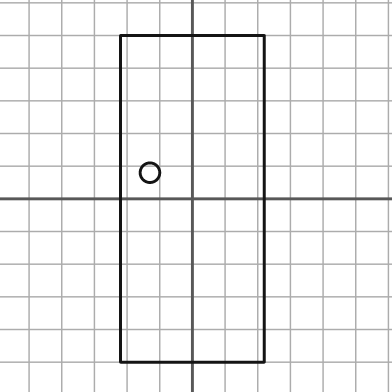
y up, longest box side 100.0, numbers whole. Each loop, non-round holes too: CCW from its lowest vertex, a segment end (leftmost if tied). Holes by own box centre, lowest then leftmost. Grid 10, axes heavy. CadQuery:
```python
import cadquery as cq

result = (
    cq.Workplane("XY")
    .moveTo(-22.0, -50.0)
    .lineTo(22.0, -50.0)
    .lineTo(22.0, 50.0)
    .lineTo(-22.0, 50.0)
    .close()
    .moveTo(-13.0, 8.0)
    .circle(3.0)
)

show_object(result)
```